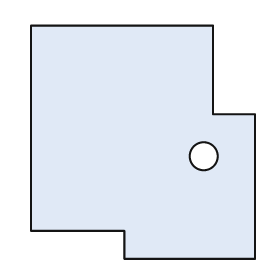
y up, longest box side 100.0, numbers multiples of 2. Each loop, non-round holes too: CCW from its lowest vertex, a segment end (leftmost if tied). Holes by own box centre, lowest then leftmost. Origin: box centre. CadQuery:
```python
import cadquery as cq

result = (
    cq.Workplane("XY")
    .moveTo(-8.0, -50.0)
    .lineTo(48.0, -50.0)
    .lineTo(48.0, 12.0)
    .lineTo(30.0, 12.0)
    .lineTo(30.0, 50.0)
    .lineTo(-48.0, 50.0)
    .lineTo(-48.0, -38.0)
    .lineTo(-8.0, -38.0)
    .close()
    .moveTo(26.0, -6.0)
    .circle(6.0)
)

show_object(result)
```